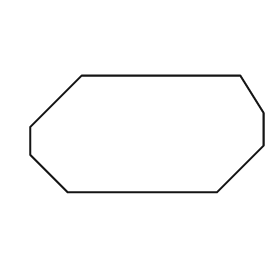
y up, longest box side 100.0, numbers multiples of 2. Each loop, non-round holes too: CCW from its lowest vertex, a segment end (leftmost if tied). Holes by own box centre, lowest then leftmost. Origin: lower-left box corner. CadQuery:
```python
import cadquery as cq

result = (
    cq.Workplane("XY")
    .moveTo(16.0, 0.0)
    .lineTo(80.0, 0.0)
    .lineTo(100.0, 20.0)
    .lineTo(100.0, 34.0)
    .lineTo(90.0, 50.0)
    .lineTo(22.0, 50.0)
    .lineTo(0.0, 28.0)
    .lineTo(0.0, 16.0)
    .close()
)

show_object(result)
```